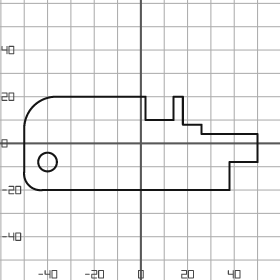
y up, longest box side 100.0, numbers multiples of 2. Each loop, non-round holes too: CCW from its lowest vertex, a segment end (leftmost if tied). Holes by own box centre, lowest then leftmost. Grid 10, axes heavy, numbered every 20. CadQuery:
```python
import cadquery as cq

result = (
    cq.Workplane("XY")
    .moveTo(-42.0, -20.0)
    .lineTo(38.0, -20.0)
    .lineTo(38.0, -8.0)
    .lineTo(50.0, -8.0)
    .lineTo(50.0, 4.0)
    .lineTo(26.0, 4.0)
    .lineTo(26.0, 8.0)
    .lineTo(18.0, 8.0)
    .lineTo(18.0, 20.0)
    .lineTo(14.0, 20.0)
    .lineTo(14.0, 10.0)
    .lineTo(2.0, 10.0)
    .lineTo(2.0, 20.0)
    .lineTo(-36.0, 20.0)
    .threePointArc((-46.0, 16.0), (-50.0, 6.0))
    .lineTo(-50.0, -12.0)
    .threePointArc((-48.0, -18.0), (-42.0, -20.0))
    .close()
    .moveTo(-40.0, -8.0)
    .circle(4.0)
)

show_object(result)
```